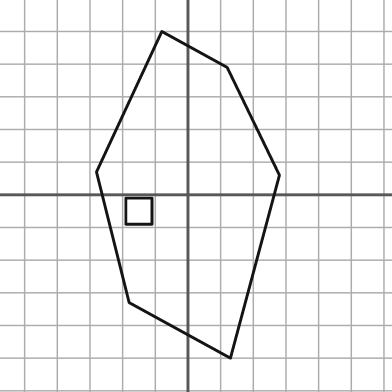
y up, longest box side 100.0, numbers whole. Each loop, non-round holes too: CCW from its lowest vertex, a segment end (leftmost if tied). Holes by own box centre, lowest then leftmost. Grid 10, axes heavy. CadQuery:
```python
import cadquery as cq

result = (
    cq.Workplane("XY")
    .moveTo(13.0, -50.0)
    .lineTo(28.0, 6.0)
    .lineTo(12.0, 39.0)
    .lineTo(-8.0, 50.0)
    .lineTo(-28.0, 7.0)
    .lineTo(-18.0, -33.0)
    .close()
    .moveTo(-19.0, -9.0)
    .lineTo(-11.0, -9.0)
    .lineTo(-11.0, -1.0)
    .lineTo(-19.0, -1.0)
    .close()
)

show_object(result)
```